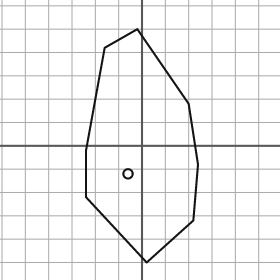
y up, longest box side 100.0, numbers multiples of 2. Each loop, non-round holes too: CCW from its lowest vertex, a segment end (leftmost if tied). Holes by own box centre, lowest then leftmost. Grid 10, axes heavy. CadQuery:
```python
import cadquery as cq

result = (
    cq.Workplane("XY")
    .moveTo(2.0, -50.0)
    .lineTo(22.0, -32.0)
    .lineTo(24.0, -8.0)
    .lineTo(20.0, 18.0)
    .lineTo(-2.0, 50.0)
    .lineTo(-16.0, 42.0)
    .lineTo(-24.0, -2.0)
    .lineTo(-24.0, -22.0)
    .close()
    .moveTo(-6.0, -12.0)
    .circle(2.0)
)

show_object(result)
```